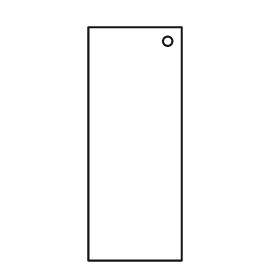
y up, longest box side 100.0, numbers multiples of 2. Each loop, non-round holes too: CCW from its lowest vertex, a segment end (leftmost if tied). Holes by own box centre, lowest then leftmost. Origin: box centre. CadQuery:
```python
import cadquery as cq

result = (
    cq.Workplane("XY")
    .moveTo(-20.0, -50.0)
    .lineTo(20.0, -50.0)
    .lineTo(20.0, 50.0)
    .lineTo(-20.0, 50.0)
    .close()
    .moveTo(14.0, 44.0)
    .circle(2.0)
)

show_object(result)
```